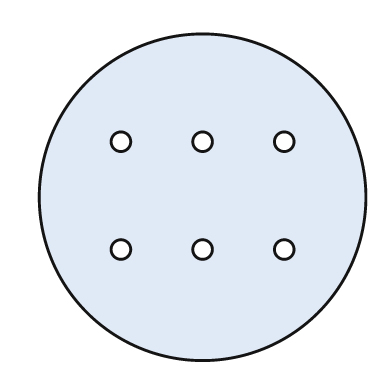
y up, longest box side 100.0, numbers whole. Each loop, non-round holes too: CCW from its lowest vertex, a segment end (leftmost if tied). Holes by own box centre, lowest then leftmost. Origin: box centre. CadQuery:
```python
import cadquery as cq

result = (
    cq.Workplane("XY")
    .moveTo(0.0, 0.0)
    .circle(50.0)
    .moveTo(-25.0, -16.0)
    .circle(3.0)
    .moveTo(0.0, -16.0)
    .circle(3.0)
    .moveTo(25.0, -16.0)
    .circle(3.0)
    .moveTo(-25.0, 17.0)
    .circle(3.0)
    .moveTo(0.0, 17.0)
    .circle(3.0)
    .moveTo(25.0, 17.0)
    .circle(3.0)
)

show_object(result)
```